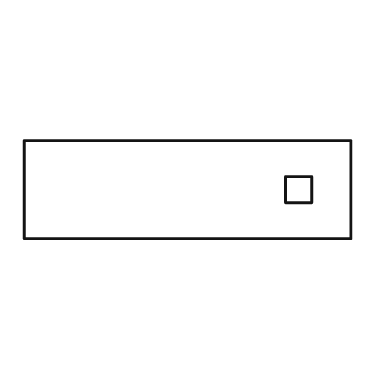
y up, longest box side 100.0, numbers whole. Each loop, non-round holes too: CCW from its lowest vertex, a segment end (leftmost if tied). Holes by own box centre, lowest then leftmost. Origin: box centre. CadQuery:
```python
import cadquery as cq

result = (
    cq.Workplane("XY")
    .moveTo(-50.0, -15.0)
    .lineTo(50.0, -15.0)
    .lineTo(50.0, 15.0)
    .lineTo(-50.0, 15.0)
    .close()
    .moveTo(30.0, -4.0)
    .lineTo(38.0, -4.0)
    .lineTo(38.0, 4.0)
    .lineTo(30.0, 4.0)
    .close()
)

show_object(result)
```